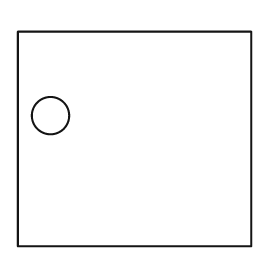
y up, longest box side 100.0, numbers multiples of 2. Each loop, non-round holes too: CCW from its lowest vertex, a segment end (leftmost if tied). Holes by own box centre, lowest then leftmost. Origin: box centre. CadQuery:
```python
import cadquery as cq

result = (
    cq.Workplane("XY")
    .moveTo(-50.0, -46.0)
    .lineTo(50.0, -46.0)
    .lineTo(50.0, 46.0)
    .lineTo(-50.0, 46.0)
    .close()
    .moveTo(-36.0, 10.0)
    .circle(8.0)
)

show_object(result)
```